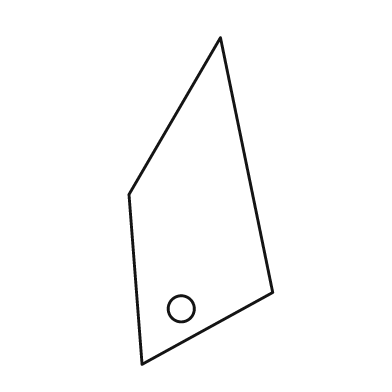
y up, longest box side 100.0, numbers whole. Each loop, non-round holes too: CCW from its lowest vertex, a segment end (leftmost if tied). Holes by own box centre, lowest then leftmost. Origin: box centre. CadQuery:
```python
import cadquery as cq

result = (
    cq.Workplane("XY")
    .moveTo(-18.0, -50.0)
    .lineTo(22.0, -28.0)
    .lineTo(6.0, 50.0)
    .lineTo(-22.0, 2.0)
    .close()
    .moveTo(-6.0, -33.0)
    .circle(4.0)
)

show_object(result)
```